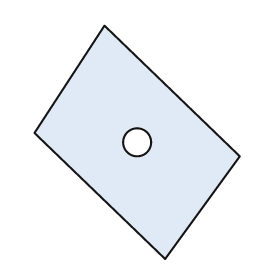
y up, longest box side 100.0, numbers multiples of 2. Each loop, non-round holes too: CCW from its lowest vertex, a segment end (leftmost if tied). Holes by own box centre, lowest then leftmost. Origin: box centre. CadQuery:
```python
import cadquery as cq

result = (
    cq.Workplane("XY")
    .moveTo(12.0, -50.0)
    .lineTo(44.0, -6.0)
    .lineTo(-14.0, 50.0)
    .lineTo(-44.0, 4.0)
    .close()
    .moveTo(0.0, 0.0)
    .circle(6.0)
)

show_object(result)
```